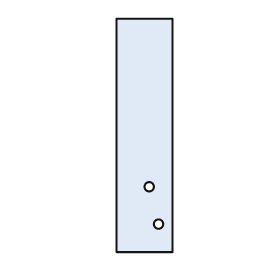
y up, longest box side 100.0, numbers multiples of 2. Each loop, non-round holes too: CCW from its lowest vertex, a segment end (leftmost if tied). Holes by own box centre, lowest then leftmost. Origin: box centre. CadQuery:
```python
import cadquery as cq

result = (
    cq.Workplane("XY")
    .moveTo(-12.0, -50.0)
    .lineTo(12.0, -50.0)
    .lineTo(12.0, 50.0)
    .lineTo(-12.0, 50.0)
    .close()
    .moveTo(6.0, -38.0)
    .circle(2.0)
    .moveTo(2.0, -22.0)
    .circle(2.0)
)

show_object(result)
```